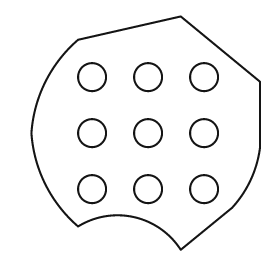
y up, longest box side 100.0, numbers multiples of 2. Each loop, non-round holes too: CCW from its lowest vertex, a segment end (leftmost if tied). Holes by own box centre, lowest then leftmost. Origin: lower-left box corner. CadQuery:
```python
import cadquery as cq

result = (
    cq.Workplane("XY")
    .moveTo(64.0, 0.0)
    .lineTo(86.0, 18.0)
    .threePointArc((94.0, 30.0), (98.0, 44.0))
    .lineTo(98.0, 72.0)
    .lineTo(64.0, 100.0)
    .lineTo(20.0, 90.0)
    .threePointArc((6.0, 72.0), (0.0, 50.0))
    .threePointArc((6.0, 28.0), (20.0, 10.0))
    .threePointArc((44.0, 14.0), (64.0, 0.0))
    .close()
    .moveTo(26.0, 26.0)
    .circle(6.0)
    .moveTo(50.0, 26.0)
    .circle(6.0)
    .moveTo(74.0, 26.0)
    .circle(6.0)
    .moveTo(26.0, 50.0)
    .circle(6.0)
    .moveTo(50.0, 50.0)
    .circle(6.0)
    .moveTo(74.0, 50.0)
    .circle(6.0)
    .moveTo(26.0, 74.0)
    .circle(6.0)
    .moveTo(50.0, 74.0)
    .circle(6.0)
    .moveTo(74.0, 74.0)
    .circle(6.0)
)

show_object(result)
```